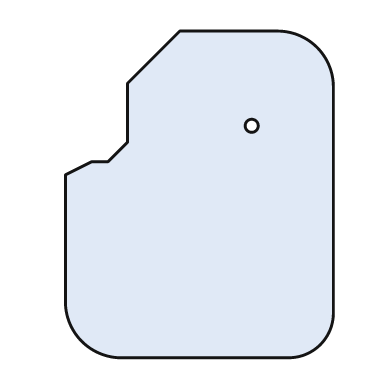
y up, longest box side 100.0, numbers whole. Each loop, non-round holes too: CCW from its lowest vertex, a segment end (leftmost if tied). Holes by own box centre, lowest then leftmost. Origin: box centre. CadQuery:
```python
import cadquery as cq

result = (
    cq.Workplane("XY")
    .moveTo(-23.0, -50.0)
    .lineTo(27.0, -50.0)
    .threePointArc((37.0, -46.0), (41.0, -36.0))
    .lineTo(41.0, 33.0)
    .threePointArc((36.0, 45.0), (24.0, 50.0))
    .lineTo(-6.0, 50.0)
    .lineTo(-22.0, 34.0)
    .lineTo(-22.0, 16.0)
    .lineTo(-28.0, 10.0)
    .lineTo(-33.0, 10.0)
    .lineTo(-41.0, 6.0)
    .lineTo(-41.0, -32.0)
    .threePointArc((-36.0, -45.0), (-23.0, -50.0))
    .close()
    .moveTo(16.0, 21.0)
    .circle(2.0)
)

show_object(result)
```